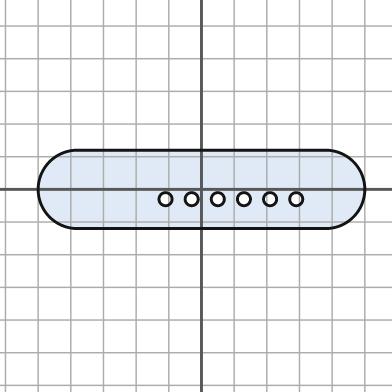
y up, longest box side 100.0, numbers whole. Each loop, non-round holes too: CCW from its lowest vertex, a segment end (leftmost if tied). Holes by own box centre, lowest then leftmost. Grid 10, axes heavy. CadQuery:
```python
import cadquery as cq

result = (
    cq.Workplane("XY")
    .moveTo(-38.0, -12.0)
    .lineTo(38.0, -12.0)
    .threePointArc((50.0, 0.0), (38.0, 12.0))
    .lineTo(-38.0, 12.0)
    .threePointArc((-50.0, 0.0), (-38.0, -12.0))
    .close()
    .moveTo(-11.0, -3.0)
    .circle(2.0)
    .moveTo(-3.0, -3.0)
    .circle(2.0)
    .moveTo(5.0, -3.0)
    .circle(2.0)
    .moveTo(13.0, -3.0)
    .circle(2.0)
    .moveTo(21.0, -3.0)
    .circle(2.0)
    .moveTo(29.0, -3.0)
    .circle(2.0)
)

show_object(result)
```